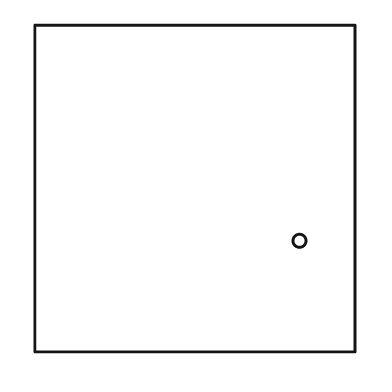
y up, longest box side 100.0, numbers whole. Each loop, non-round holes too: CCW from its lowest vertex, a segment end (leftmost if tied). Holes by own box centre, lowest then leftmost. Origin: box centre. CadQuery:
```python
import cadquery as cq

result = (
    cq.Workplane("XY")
    .moveTo(-49.0, -50.0)
    .lineTo(49.0, -50.0)
    .lineTo(49.0, 50.0)
    .lineTo(-49.0, 50.0)
    .close()
    .moveTo(32.0, -16.0)
    .circle(2.0)
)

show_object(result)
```